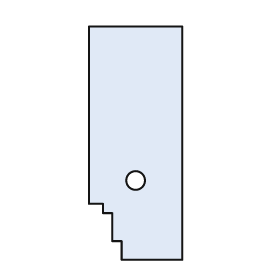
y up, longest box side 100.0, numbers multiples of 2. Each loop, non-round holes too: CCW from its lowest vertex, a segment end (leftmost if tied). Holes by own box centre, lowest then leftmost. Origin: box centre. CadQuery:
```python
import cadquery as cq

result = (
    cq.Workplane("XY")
    .moveTo(-6.0, -50.0)
    .lineTo(20.0, -50.0)
    .lineTo(20.0, 50.0)
    .lineTo(-20.0, 50.0)
    .lineTo(-20.0, -26.0)
    .lineTo(-14.0, -26.0)
    .lineTo(-14.0, -30.0)
    .lineTo(-10.0, -30.0)
    .lineTo(-10.0, -42.0)
    .lineTo(-6.0, -42.0)
    .close()
    .moveTo(0.0, -16.0)
    .circle(4.0)
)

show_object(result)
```